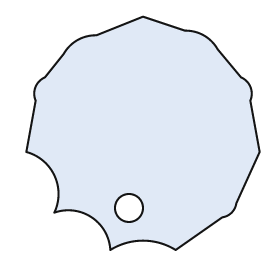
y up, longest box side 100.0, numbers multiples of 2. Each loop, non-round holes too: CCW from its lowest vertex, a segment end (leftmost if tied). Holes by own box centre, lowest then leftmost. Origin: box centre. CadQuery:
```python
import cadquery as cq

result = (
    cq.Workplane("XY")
    .moveTo(-14.0, -50.0)
    .threePointArc((0.0, -46.0), (14.0, -50.0))
    .lineTo(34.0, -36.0)
    .threePointArc((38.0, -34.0), (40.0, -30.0))
    .lineTo(50.0, -8.0)
    .lineTo(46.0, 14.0)
    .threePointArc((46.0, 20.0), (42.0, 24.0))
    .lineTo(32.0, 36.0)
    .threePointArc((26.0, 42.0), (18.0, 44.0))
    .lineTo(0.0, 50.0)
    .lineTo(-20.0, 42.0)
    .threePointArc((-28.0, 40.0), (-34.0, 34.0))
    .lineTo(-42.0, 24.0)
    .threePointArc((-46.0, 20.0), (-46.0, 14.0))
    .lineTo(-50.0, -8.0)
    .threePointArc((-38.0, -18.0), (-38.0, -34.0))
    .threePointArc((-22.0, -36.0), (-14.0, -50.0))
    .close()
    .moveTo(-6.0, -32.0)
    .circle(6.0)
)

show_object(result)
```